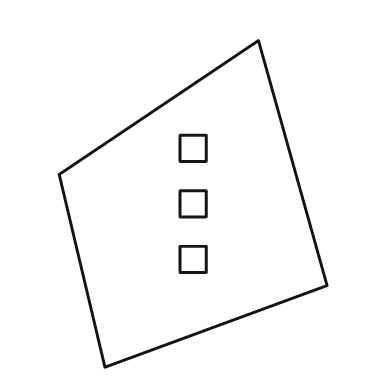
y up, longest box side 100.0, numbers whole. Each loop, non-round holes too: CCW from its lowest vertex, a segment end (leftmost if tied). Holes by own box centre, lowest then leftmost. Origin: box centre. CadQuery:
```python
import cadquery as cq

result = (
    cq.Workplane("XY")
    .moveTo(-27.0, -50.0)
    .lineTo(41.0, -25.0)
    .lineTo(20.0, 50.0)
    .lineTo(-41.0, 9.0)
    .close()
    .moveTo(-4.0, -21.0)
    .lineTo(4.0, -21.0)
    .lineTo(4.0, -13.0)
    .lineTo(-4.0, -13.0)
    .close()
    .moveTo(-4.0, -4.0)
    .lineTo(4.0, -4.0)
    .lineTo(4.0, 4.0)
    .lineTo(-4.0, 4.0)
    .close()
    .moveTo(-4.0, 13.0)
    .lineTo(4.0, 13.0)
    .lineTo(4.0, 21.0)
    .lineTo(-4.0, 21.0)
    .close()
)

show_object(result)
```